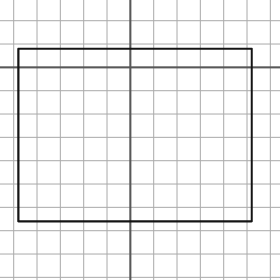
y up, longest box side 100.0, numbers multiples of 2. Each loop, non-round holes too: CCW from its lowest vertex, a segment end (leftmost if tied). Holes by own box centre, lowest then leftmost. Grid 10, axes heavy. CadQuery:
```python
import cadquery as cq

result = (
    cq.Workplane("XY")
    .moveTo(-48.0, -66.0)
    .lineTo(52.0, -66.0)
    .lineTo(52.0, 8.0)
    .lineTo(-48.0, 8.0)
    .close()
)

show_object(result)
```